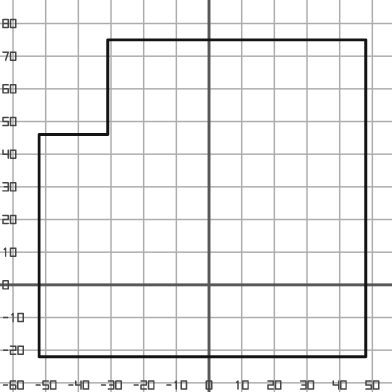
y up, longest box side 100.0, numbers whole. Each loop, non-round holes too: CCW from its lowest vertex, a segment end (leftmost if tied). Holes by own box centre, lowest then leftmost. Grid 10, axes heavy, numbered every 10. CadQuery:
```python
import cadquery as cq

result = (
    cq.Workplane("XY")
    .moveTo(-52.0, -22.0)
    .lineTo(48.0, -22.0)
    .lineTo(48.0, 75.0)
    .lineTo(-31.0, 75.0)
    .lineTo(-31.0, 46.0)
    .lineTo(-52.0, 46.0)
    .close()
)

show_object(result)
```